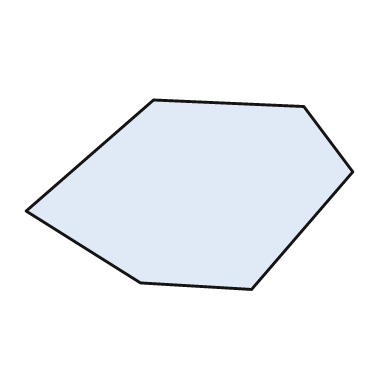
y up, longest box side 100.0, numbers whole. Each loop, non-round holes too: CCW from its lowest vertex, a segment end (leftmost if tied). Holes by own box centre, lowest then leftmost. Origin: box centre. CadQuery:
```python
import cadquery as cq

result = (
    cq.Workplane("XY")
    .moveTo(19.0, -29.0)
    .lineTo(50.0, 7.0)
    .lineTo(35.0, 27.0)
    .lineTo(-11.0, 29.0)
    .lineTo(-50.0, -5.0)
    .lineTo(-15.0, -27.0)
    .close()
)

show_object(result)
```